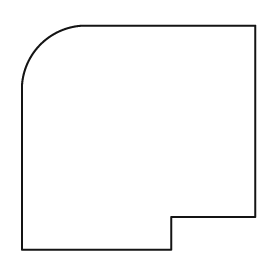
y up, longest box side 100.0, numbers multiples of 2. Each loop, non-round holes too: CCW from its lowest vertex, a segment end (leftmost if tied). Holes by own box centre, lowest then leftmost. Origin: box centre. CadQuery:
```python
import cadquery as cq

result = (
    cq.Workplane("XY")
    .moveTo(-50.0, -48.0)
    .lineTo(14.0, -48.0)
    .lineTo(14.0, -34.0)
    .lineTo(50.0, -34.0)
    .lineTo(50.0, 48.0)
    .lineTo(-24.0, 48.0)
    .threePointArc((-42.0, 40.0), (-50.0, 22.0))
    .close()
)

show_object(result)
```